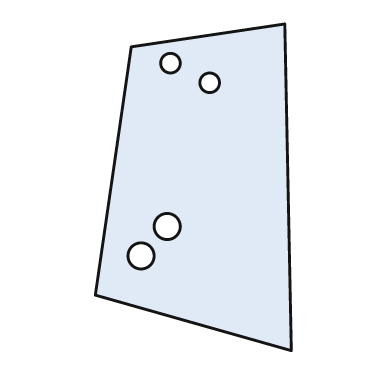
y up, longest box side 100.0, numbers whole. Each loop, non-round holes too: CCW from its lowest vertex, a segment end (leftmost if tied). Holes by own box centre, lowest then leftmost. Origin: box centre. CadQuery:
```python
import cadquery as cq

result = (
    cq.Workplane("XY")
    .moveTo(30.0, -50.0)
    .lineTo(28.0, 50.0)
    .lineTo(-19.0, 43.0)
    .lineTo(-30.0, -33.0)
    .close()
    .moveTo(-16.0, -21.0)
    .circle(4.0)
    .moveTo(-8.0, -12.0)
    .circle(4.0)
    .moveTo(5.0, 32.0)
    .circle(3.0)
    .moveTo(-7.0, 38.0)
    .circle(3.0)
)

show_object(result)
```